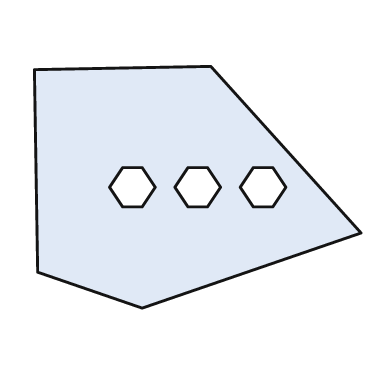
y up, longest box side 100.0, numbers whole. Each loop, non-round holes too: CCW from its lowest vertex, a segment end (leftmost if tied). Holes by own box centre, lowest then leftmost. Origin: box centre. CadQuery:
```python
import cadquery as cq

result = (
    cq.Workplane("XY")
    .moveTo(-17.0, -37.0)
    .lineTo(50.0, -14.0)
    .lineTo(4.0, 37.0)
    .lineTo(-50.0, 36.0)
    .lineTo(-49.0, -26.0)
    .close()
    .moveTo(-23.0, -6.0)
    .lineTo(-17.0, -6.0)
    .lineTo(-13.0, 0.0)
    .lineTo(-17.0, 6.0)
    .lineTo(-23.0, 6.0)
    .lineTo(-27.0, 0.0)
    .close()
    .moveTo(-3.0, -6.0)
    .lineTo(3.0, -6.0)
    .lineTo(7.0, 0.0)
    .lineTo(3.0, 6.0)
    .lineTo(-3.0, 6.0)
    .lineTo(-7.0, 0.0)
    .close()
    .moveTo(17.0, -6.0)
    .lineTo(23.0, -6.0)
    .lineTo(27.0, 0.0)
    .lineTo(23.0, 6.0)
    .lineTo(17.0, 6.0)
    .lineTo(13.0, 0.0)
    .close()
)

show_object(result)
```